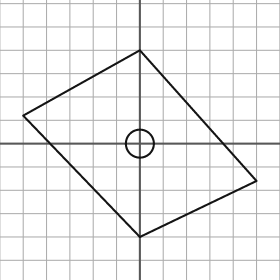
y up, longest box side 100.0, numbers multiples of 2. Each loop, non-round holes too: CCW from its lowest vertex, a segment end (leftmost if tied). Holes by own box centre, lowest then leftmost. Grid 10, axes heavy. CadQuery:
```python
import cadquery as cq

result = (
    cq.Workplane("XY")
    .moveTo(0.0, -40.0)
    .lineTo(50.0, -16.0)
    .lineTo(0.0, 40.0)
    .lineTo(-50.0, 12.0)
    .close()
    .moveTo(0.0, 0.0)
    .circle(6.0)
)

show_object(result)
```